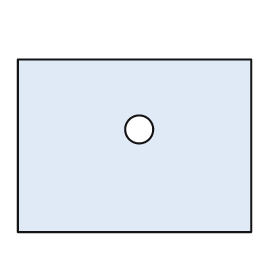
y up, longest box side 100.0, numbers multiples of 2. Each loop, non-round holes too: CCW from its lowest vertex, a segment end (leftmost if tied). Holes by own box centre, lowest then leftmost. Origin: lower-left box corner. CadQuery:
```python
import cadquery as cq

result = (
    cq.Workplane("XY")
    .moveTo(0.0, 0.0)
    .lineTo(100.0, 0.0)
    .lineTo(100.0, 74.0)
    .lineTo(0.0, 74.0)
    .close()
    .moveTo(52.0, 44.0)
    .circle(6.0)
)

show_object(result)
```